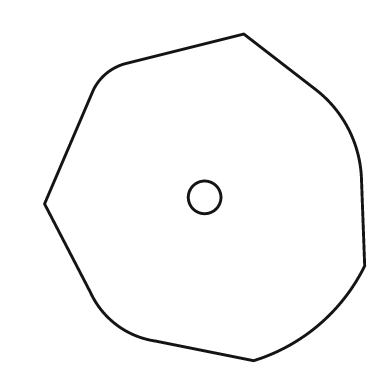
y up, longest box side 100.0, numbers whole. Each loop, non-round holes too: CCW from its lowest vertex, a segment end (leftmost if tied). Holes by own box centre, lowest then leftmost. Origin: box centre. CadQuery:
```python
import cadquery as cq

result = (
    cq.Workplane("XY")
    .moveTo(15.0, -50.0)
    .threePointArc((35.0, -39.0), (49.0, -21.0))
    .lineTo(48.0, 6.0)
    .threePointArc((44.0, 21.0), (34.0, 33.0))
    .lineTo(12.0, 50.0)
    .lineTo(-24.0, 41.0)
    .threePointArc((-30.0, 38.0), (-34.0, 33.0))
    .lineTo(-49.0, -2.0)
    .lineTo(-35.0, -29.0)
    .threePointArc((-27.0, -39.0), (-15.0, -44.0))
    .close()
    .moveTo(0.0, 0.0)
    .circle(5.0)
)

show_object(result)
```